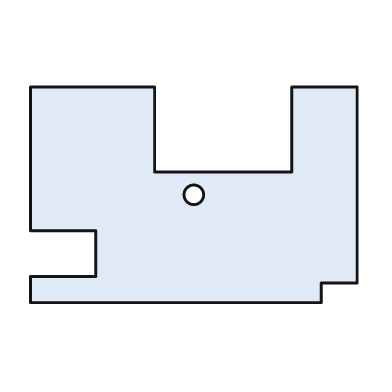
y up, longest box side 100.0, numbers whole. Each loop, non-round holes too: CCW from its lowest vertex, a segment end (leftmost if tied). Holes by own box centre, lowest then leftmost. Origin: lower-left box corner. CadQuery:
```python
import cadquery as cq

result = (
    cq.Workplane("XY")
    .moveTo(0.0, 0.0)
    .lineTo(89.0, 0.0)
    .lineTo(89.0, 6.0)
    .lineTo(100.0, 6.0)
    .lineTo(100.0, 66.0)
    .lineTo(80.0, 66.0)
    .lineTo(80.0, 40.0)
    .lineTo(38.0, 40.0)
    .lineTo(38.0, 66.0)
    .lineTo(0.0, 66.0)
    .lineTo(0.0, 22.0)
    .lineTo(20.0, 22.0)
    .lineTo(20.0, 8.0)
    .lineTo(0.0, 8.0)
    .close()
    .moveTo(50.0, 33.0)
    .circle(3.0)
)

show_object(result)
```